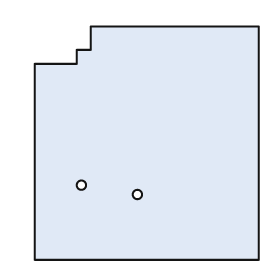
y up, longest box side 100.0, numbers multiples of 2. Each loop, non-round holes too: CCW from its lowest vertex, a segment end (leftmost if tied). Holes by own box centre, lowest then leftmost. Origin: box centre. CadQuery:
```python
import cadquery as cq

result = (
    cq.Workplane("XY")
    .moveTo(-48.0, -50.0)
    .lineTo(48.0, -50.0)
    .lineTo(48.0, 50.0)
    .lineTo(-24.0, 50.0)
    .lineTo(-24.0, 40.0)
    .lineTo(-30.0, 40.0)
    .lineTo(-30.0, 34.0)
    .lineTo(-48.0, 34.0)
    .close()
    .moveTo(-4.0, -22.0)
    .circle(2.0)
    .moveTo(-28.0, -18.0)
    .circle(2.0)
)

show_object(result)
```